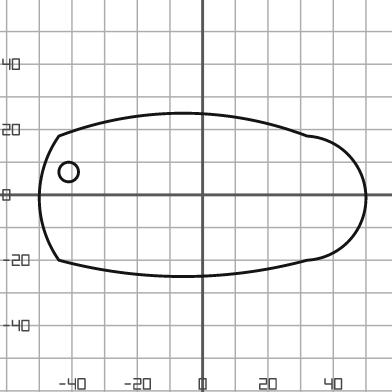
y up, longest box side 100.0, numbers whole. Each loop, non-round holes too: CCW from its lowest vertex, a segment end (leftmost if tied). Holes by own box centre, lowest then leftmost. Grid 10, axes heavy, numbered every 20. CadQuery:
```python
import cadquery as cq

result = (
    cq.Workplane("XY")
    .moveTo(-44.0, -20.0)
    .threePointArc((-6.0, -25.0), (32.0, -20.0))
    .threePointArc((50.0, -1.0), (32.0, 18.0))
    .threePointArc((-6.0, 25.0), (-44.0, 18.0))
    .threePointArc((-50.0, -1.0), (-44.0, -20.0))
    .close()
    .moveTo(-41.0, 7.0)
    .circle(3.0)
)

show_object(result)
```